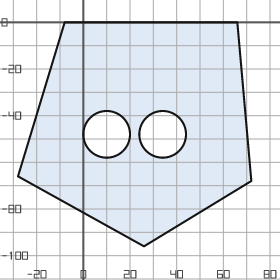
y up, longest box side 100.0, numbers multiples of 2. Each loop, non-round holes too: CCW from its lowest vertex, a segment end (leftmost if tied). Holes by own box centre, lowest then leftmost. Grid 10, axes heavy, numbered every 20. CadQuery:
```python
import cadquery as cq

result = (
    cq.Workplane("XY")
    .moveTo(26.0, -96.0)
    .lineTo(72.0, -68.0)
    .lineTo(66.0, 0.0)
    .lineTo(-8.0, 0.0)
    .lineTo(-28.0, -66.0)
    .close()
    .moveTo(10.0, -48.0)
    .circle(10.0)
    .moveTo(34.0, -48.0)
    .circle(10.0)
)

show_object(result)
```